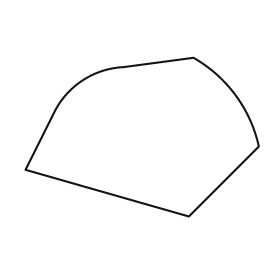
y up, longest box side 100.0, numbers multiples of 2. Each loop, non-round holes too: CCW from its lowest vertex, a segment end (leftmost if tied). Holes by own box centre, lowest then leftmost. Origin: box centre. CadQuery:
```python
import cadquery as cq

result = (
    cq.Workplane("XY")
    .moveTo(20.0, -34.0)
    .lineTo(50.0, -4.0)
    .threePointArc((40.0, 18.0), (22.0, 34.0))
    .lineTo(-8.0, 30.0)
    .threePointArc((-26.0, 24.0), (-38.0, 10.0))
    .lineTo(-50.0, -14.0)
    .close()
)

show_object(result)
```